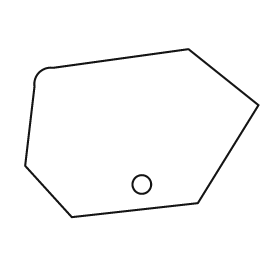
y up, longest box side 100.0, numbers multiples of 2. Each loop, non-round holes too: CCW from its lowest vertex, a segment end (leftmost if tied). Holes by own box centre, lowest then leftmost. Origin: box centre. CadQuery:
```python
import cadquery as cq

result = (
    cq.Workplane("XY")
    .moveTo(-30.0, -36.0)
    .lineTo(24.0, -30.0)
    .lineTo(50.0, 12.0)
    .lineTo(20.0, 36.0)
    .lineTo(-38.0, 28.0)
    .threePointArc((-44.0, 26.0), (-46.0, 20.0))
    .lineTo(-50.0, -14.0)
    .close()
    .moveTo(0.0, -22.0)
    .circle(4.0)
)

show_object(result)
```